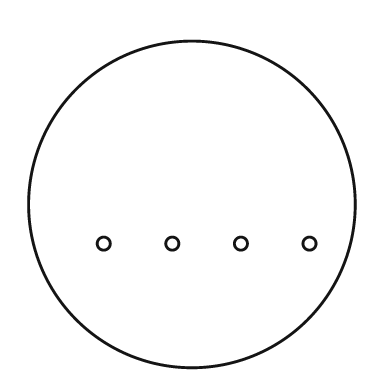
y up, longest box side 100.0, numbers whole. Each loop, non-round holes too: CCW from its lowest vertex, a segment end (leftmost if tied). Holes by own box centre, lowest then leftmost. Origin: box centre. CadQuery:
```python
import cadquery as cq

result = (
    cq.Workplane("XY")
    .moveTo(0.0, 0.0)
    .circle(50.0)
    .moveTo(-27.0, -12.0)
    .circle(2.0)
    .moveTo(-6.0, -12.0)
    .circle(2.0)
    .moveTo(15.0, -12.0)
    .circle(2.0)
    .moveTo(36.0, -12.0)
    .circle(2.0)
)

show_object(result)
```